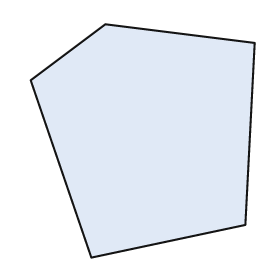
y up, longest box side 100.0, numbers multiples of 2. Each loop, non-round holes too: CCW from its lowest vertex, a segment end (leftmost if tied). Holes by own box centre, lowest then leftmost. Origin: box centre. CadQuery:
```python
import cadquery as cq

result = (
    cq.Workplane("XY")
    .moveTo(-22.0, -50.0)
    .lineTo(44.0, -36.0)
    .lineTo(48.0, 42.0)
    .lineTo(-16.0, 50.0)
    .lineTo(-48.0, 26.0)
    .close()
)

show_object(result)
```